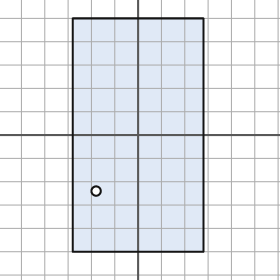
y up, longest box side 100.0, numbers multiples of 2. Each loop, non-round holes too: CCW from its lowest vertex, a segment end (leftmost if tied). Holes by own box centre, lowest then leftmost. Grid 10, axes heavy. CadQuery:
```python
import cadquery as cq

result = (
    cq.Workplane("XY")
    .moveTo(-28.0, -50.0)
    .lineTo(28.0, -50.0)
    .lineTo(28.0, 50.0)
    .lineTo(-28.0, 50.0)
    .close()
    .moveTo(-18.0, -24.0)
    .circle(2.0)
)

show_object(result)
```